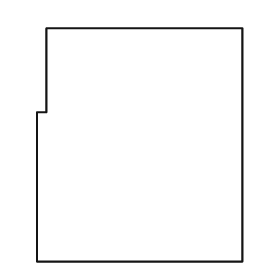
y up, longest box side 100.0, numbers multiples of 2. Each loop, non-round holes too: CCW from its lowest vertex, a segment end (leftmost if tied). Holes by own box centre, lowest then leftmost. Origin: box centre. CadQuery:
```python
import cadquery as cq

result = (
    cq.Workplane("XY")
    .moveTo(-44.0, -50.0)
    .lineTo(44.0, -50.0)
    .lineTo(44.0, 50.0)
    .lineTo(-40.0, 50.0)
    .lineTo(-40.0, 14.0)
    .lineTo(-44.0, 14.0)
    .close()
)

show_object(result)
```